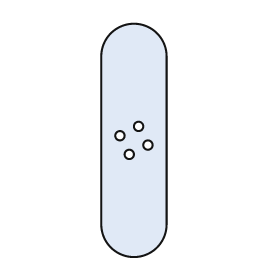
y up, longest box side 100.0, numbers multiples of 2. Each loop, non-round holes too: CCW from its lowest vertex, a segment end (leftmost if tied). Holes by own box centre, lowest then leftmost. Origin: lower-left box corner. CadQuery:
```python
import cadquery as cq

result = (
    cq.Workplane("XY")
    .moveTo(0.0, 14.0)
    .threePointArc((14.0, 0.0), (28.0, 14.0))
    .lineTo(28.0, 86.0)
    .threePointArc((14.0, 100.0), (0.0, 86.0))
    .close()
    .moveTo(12.0, 44.0)
    .circle(2.0)
    .moveTo(20.0, 48.0)
    .circle(2.0)
    .moveTo(8.0, 52.0)
    .circle(2.0)
    .moveTo(16.0, 56.0)
    .circle(2.0)
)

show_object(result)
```